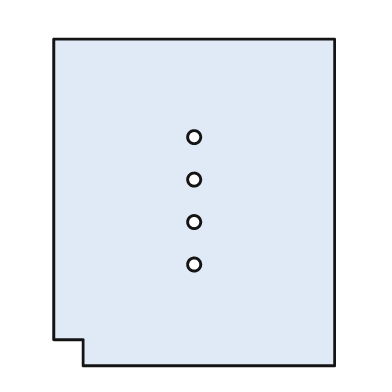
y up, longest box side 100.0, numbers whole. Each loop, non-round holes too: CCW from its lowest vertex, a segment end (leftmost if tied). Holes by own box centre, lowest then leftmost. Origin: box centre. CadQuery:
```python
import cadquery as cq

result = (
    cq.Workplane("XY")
    .moveTo(-34.0, -50.0)
    .lineTo(43.0, -50.0)
    .lineTo(43.0, 50.0)
    .lineTo(-43.0, 50.0)
    .lineTo(-43.0, -42.0)
    .lineTo(-34.0, -42.0)
    .close()
    .moveTo(0.0, -19.0)
    .circle(2.0)
    .moveTo(0.0, -6.0)
    .circle(2.0)
    .moveTo(0.0, 7.0)
    .circle(2.0)
    .moveTo(0.0, 20.0)
    .circle(2.0)
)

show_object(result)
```